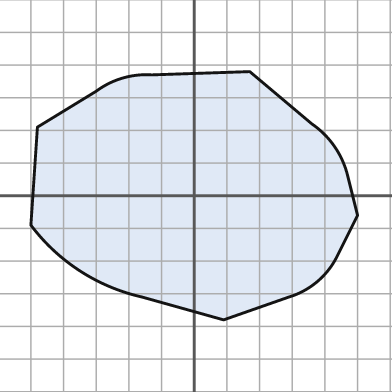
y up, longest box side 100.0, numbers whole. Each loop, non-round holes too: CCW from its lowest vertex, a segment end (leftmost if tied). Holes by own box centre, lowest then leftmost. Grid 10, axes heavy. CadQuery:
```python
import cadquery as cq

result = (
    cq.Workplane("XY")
    .moveTo(9.0, -38.0)
    .lineTo(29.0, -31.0)
    .threePointArc((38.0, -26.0), (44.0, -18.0))
    .lineTo(50.0, -6.0)
    .lineTo(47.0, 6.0)
    .threePointArc((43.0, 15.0), (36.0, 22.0))
    .lineTo(17.0, 38.0)
    .lineTo(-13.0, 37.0)
    .threePointArc((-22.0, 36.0), (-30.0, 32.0))
    .lineTo(-48.0, 21.0)
    .lineTo(-50.0, -9.0)
    .threePointArc((-35.0, -23.0), (-16.0, -31.0))
    .close()
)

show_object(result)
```